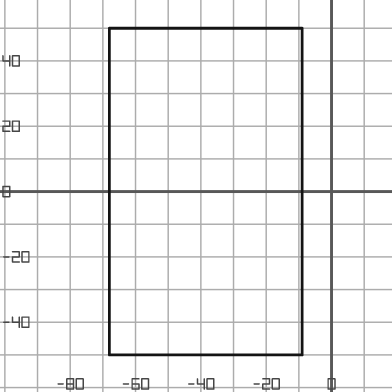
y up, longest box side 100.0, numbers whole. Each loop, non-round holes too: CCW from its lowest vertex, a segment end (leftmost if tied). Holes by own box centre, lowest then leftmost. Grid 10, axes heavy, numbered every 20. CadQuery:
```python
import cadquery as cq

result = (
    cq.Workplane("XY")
    .moveTo(-68.0, -50.0)
    .lineTo(-9.0, -50.0)
    .lineTo(-9.0, 50.0)
    .lineTo(-68.0, 50.0)
    .close()
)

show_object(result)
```